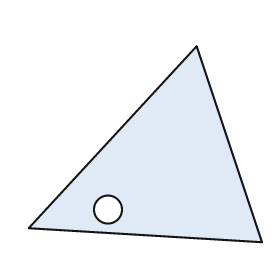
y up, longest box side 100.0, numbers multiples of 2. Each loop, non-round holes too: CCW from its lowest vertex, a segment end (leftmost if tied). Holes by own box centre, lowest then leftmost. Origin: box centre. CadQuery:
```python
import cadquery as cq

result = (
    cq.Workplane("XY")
    .moveTo(50.0, -42.0)
    .lineTo(22.0, 42.0)
    .lineTo(-50.0, -36.0)
    .close()
    .moveTo(-16.0, -28.0)
    .circle(6.0)
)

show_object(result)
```